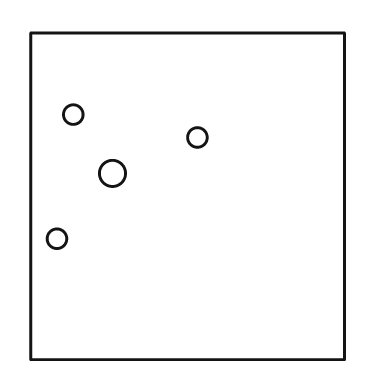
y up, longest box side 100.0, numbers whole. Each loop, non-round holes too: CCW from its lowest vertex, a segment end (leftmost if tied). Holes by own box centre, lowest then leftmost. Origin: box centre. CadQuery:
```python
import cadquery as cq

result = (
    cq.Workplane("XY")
    .moveTo(-48.0, -50.0)
    .lineTo(48.0, -50.0)
    .lineTo(48.0, 50.0)
    .lineTo(-48.0, 50.0)
    .close()
    .moveTo(-40.0, -13.0)
    .circle(3.0)
    .moveTo(-23.0, 7.0)
    .circle(4.0)
    .moveTo(3.0, 18.0)
    .circle(3.0)
    .moveTo(-35.0, 25.0)
    .circle(3.0)
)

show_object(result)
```